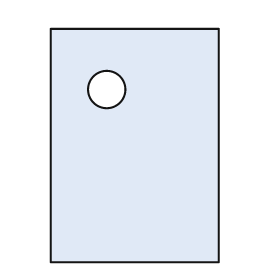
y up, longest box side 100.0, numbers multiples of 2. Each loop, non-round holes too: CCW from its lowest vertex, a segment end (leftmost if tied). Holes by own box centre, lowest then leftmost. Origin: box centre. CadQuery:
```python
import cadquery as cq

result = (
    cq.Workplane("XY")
    .moveTo(-36.0, -50.0)
    .lineTo(36.0, -50.0)
    .lineTo(36.0, 50.0)
    .lineTo(-36.0, 50.0)
    .close()
    .moveTo(-12.0, 24.0)
    .circle(8.0)
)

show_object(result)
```